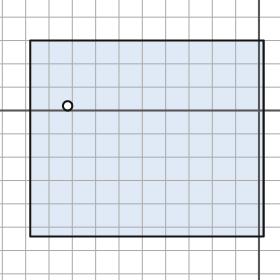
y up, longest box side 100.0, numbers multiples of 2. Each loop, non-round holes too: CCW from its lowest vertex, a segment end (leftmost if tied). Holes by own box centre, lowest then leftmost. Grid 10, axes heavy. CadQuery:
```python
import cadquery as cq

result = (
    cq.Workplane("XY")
    .moveTo(-98.0, -54.0)
    .lineTo(2.0, -54.0)
    .lineTo(2.0, 30.0)
    .lineTo(-98.0, 30.0)
    .close()
    .moveTo(-82.0, 2.0)
    .circle(2.0)
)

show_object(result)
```